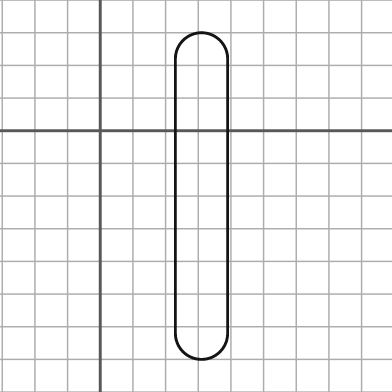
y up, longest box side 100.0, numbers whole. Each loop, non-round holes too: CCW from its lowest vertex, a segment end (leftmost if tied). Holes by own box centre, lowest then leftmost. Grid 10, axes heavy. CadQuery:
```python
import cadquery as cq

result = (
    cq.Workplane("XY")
    .moveTo(23.0, -62.0)
    .threePointArc((31.0, -70.0), (39.0, -62.0))
    .lineTo(39.0, 22.0)
    .threePointArc((31.0, 30.0), (23.0, 22.0))
    .close()
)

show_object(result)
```